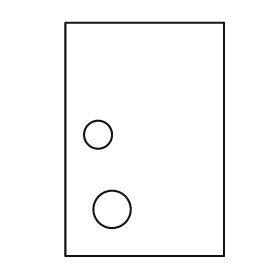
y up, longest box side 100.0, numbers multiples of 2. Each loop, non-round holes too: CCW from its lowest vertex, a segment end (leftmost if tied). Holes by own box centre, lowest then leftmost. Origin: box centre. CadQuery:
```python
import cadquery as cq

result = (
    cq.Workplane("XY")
    .moveTo(-34.0, -50.0)
    .lineTo(34.0, -50.0)
    .lineTo(34.0, 50.0)
    .lineTo(-34.0, 50.0)
    .close()
    .moveTo(-14.0, -30.0)
    .circle(8.0)
    .moveTo(-20.0, 2.0)
    .circle(6.0)
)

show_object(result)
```